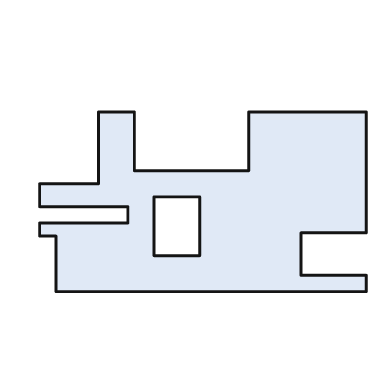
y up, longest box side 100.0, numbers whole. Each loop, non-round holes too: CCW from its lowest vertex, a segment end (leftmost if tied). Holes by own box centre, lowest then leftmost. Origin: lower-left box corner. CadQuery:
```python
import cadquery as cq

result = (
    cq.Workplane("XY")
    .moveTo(5.0, 0.0)
    .lineTo(100.0, 0.0)
    .lineTo(100.0, 5.0)
    .lineTo(80.0, 5.0)
    .lineTo(80.0, 18.0)
    .lineTo(100.0, 18.0)
    .lineTo(100.0, 55.0)
    .lineTo(64.0, 55.0)
    .lineTo(64.0, 37.0)
    .lineTo(29.0, 37.0)
    .lineTo(29.0, 55.0)
    .lineTo(18.0, 55.0)
    .lineTo(18.0, 33.0)
    .lineTo(0.0, 33.0)
    .lineTo(0.0, 26.0)
    .lineTo(27.0, 26.0)
    .lineTo(27.0, 21.0)
    .lineTo(0.0, 21.0)
    .lineTo(0.0, 17.0)
    .lineTo(5.0, 17.0)
    .close()
    .moveTo(35.0, 11.0)
    .lineTo(49.0, 11.0)
    .lineTo(49.0, 29.0)
    .lineTo(35.0, 29.0)
    .close()
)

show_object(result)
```